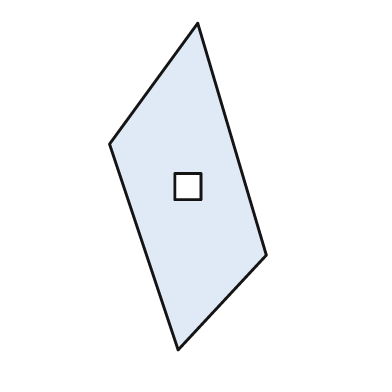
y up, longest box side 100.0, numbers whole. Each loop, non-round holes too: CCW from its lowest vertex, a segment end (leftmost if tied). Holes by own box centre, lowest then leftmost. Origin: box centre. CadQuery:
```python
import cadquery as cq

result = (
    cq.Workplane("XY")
    .moveTo(-3.0, -50.0)
    .lineTo(24.0, -21.0)
    .lineTo(3.0, 50.0)
    .lineTo(-24.0, 13.0)
    .close()
    .moveTo(-4.0, -4.0)
    .lineTo(4.0, -4.0)
    .lineTo(4.0, 4.0)
    .lineTo(-4.0, 4.0)
    .close()
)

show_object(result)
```